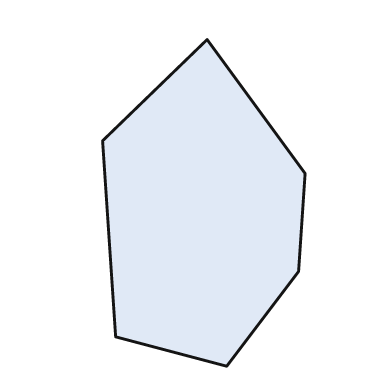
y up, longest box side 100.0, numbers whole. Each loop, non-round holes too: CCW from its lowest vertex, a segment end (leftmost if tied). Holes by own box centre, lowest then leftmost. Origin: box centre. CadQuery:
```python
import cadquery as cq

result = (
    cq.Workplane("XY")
    .moveTo(7.0, -50.0)
    .lineTo(29.0, -21.0)
    .lineTo(31.0, 9.0)
    .lineTo(1.0, 50.0)
    .lineTo(-31.0, 19.0)
    .lineTo(-27.0, -41.0)
    .close()
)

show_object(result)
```